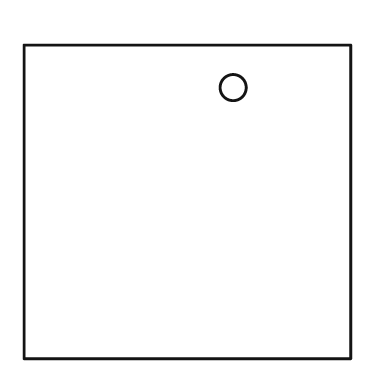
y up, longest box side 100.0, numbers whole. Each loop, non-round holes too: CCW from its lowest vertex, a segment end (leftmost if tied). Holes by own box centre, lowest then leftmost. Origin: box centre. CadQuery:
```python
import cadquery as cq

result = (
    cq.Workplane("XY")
    .moveTo(-50.0, -48.0)
    .lineTo(50.0, -48.0)
    .lineTo(50.0, 48.0)
    .lineTo(-50.0, 48.0)
    .close()
    .moveTo(14.0, 35.0)
    .circle(4.0)
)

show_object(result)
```